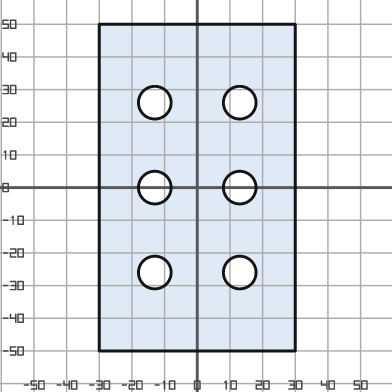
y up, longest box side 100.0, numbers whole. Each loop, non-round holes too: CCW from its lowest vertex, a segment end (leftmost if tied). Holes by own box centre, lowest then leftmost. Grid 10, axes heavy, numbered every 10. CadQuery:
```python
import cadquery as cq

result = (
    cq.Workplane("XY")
    .moveTo(-30.0, -50.0)
    .lineTo(30.0, -50.0)
    .lineTo(30.0, 50.0)
    .lineTo(-30.0, 50.0)
    .close()
    .moveTo(-13.0, -26.0)
    .circle(5.0)
    .moveTo(13.0, -26.0)
    .circle(5.0)
    .moveTo(-13.0, 0.0)
    .circle(5.0)
    .moveTo(13.0, 0.0)
    .circle(5.0)
    .moveTo(-13.0, 26.0)
    .circle(5.0)
    .moveTo(13.0, 26.0)
    .circle(5.0)
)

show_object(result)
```